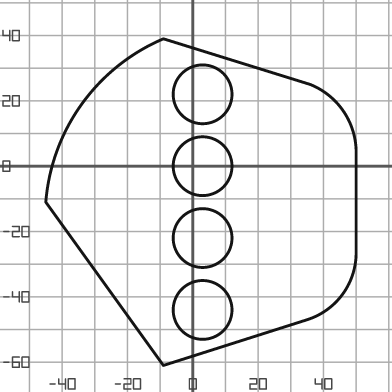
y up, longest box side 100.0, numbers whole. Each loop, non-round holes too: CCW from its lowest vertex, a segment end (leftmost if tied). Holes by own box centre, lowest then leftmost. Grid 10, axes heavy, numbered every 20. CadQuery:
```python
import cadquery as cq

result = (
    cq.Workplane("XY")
    .moveTo(-9.0, -61.0)
    .lineTo(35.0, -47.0)
    .threePointArc((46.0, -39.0), (50.0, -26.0))
    .lineTo(50.0, 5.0)
    .threePointArc((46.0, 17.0), (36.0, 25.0))
    .lineTo(-9.0, 39.0)
    .threePointArc((-34.0, 19.0), (-45.0, -11.0))
    .close()
    .moveTo(3.0, -44.0)
    .circle(9.0)
    .moveTo(3.0, -22.0)
    .circle(9.0)
    .moveTo(3.0, 0.0)
    .circle(9.0)
    .moveTo(3.0, 22.0)
    .circle(9.0)
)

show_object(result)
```